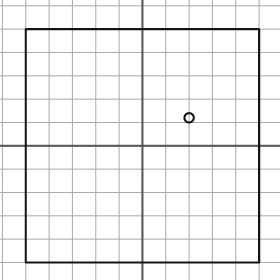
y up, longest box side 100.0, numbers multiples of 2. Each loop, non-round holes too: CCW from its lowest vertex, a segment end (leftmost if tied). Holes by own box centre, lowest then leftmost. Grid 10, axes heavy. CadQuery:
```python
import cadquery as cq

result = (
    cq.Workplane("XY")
    .moveTo(-50.0, -50.0)
    .lineTo(50.0, -50.0)
    .lineTo(50.0, 50.0)
    .lineTo(-50.0, 50.0)
    .close()
    .moveTo(20.0, 12.0)
    .circle(2.0)
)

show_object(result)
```